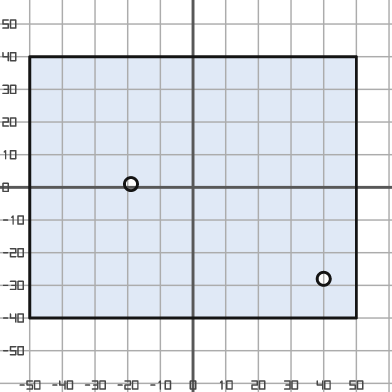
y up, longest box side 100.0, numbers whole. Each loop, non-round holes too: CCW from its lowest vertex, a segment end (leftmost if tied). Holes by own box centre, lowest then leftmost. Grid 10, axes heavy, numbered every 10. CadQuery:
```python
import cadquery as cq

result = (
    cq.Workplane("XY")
    .moveTo(-50.0, -40.0)
    .lineTo(50.0, -40.0)
    .lineTo(50.0, 40.0)
    .lineTo(-50.0, 40.0)
    .close()
    .moveTo(40.0, -28.0)
    .circle(2.0)
    .moveTo(-19.0, 1.0)
    .circle(2.0)
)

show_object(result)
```